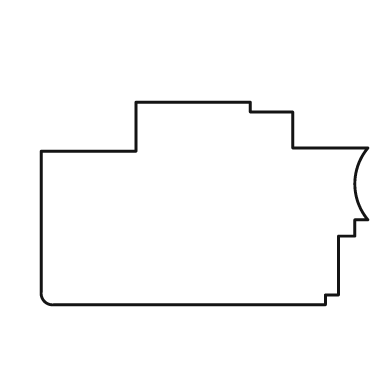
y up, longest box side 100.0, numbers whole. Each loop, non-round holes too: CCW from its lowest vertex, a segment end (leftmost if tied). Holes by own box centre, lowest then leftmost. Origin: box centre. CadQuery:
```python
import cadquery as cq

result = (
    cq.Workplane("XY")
    .moveTo(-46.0, -31.0)
    .lineTo(37.0, -31.0)
    .lineTo(37.0, -28.0)
    .lineTo(41.0, -28.0)
    .lineTo(41.0, -10.0)
    .lineTo(46.0, -10.0)
    .lineTo(46.0, -5.0)
    .lineTo(50.0, -5.0)
    .threePointArc((46.0, 6.0), (50.0, 17.0))
    .lineTo(27.0, 17.0)
    .lineTo(27.0, 28.0)
    .lineTo(14.0, 28.0)
    .lineTo(14.0, 31.0)
    .lineTo(-21.0, 31.0)
    .lineTo(-21.0, 16.0)
    .lineTo(-50.0, 16.0)
    .lineTo(-50.0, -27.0)
    .threePointArc((-49.0, -30.0), (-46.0, -31.0))
    .close()
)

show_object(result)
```